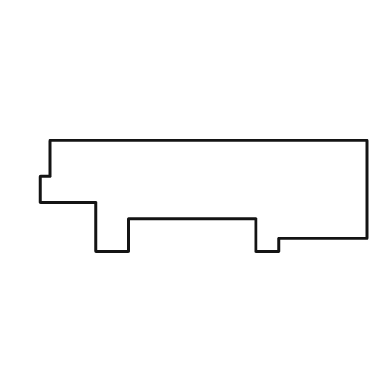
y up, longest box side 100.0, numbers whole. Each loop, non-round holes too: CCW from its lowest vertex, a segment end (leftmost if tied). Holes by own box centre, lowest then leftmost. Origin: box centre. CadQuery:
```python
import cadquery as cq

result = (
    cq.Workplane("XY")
    .moveTo(-33.0, -17.0)
    .lineTo(-23.0, -17.0)
    .lineTo(-23.0, -7.0)
    .lineTo(16.0, -7.0)
    .lineTo(16.0, -17.0)
    .lineTo(23.0, -17.0)
    .lineTo(23.0, -13.0)
    .lineTo(50.0, -13.0)
    .lineTo(50.0, 17.0)
    .lineTo(-47.0, 17.0)
    .lineTo(-47.0, 6.0)
    .lineTo(-50.0, 6.0)
    .lineTo(-50.0, -2.0)
    .lineTo(-33.0, -2.0)
    .close()
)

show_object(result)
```